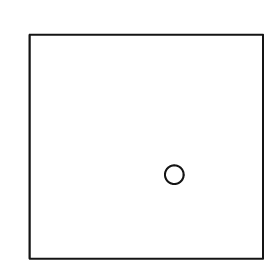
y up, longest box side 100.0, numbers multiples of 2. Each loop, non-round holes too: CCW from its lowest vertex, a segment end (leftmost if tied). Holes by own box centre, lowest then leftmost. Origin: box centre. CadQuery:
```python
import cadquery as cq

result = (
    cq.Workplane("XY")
    .moveTo(-50.0, -48.0)
    .lineTo(50.0, -48.0)
    .lineTo(50.0, 48.0)
    .lineTo(-50.0, 48.0)
    .close()
    .moveTo(12.0, -12.0)
    .circle(4.0)
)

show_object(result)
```